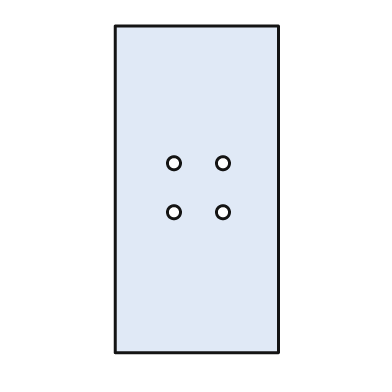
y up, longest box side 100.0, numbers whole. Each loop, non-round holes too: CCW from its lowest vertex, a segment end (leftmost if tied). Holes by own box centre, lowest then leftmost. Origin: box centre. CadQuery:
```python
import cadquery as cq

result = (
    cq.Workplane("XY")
    .moveTo(-25.0, -50.0)
    .lineTo(25.0, -50.0)
    .lineTo(25.0, 50.0)
    .lineTo(-25.0, 50.0)
    .close()
    .moveTo(-7.0, -7.0)
    .circle(2.0)
    .moveTo(8.0, -7.0)
    .circle(2.0)
    .moveTo(-7.0, 8.0)
    .circle(2.0)
    .moveTo(8.0, 8.0)
    .circle(2.0)
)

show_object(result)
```